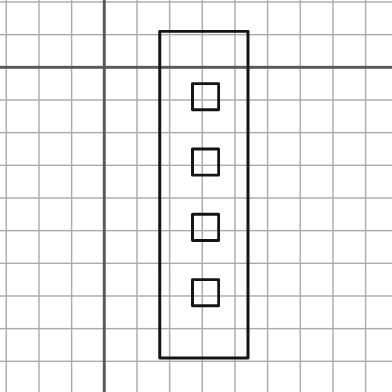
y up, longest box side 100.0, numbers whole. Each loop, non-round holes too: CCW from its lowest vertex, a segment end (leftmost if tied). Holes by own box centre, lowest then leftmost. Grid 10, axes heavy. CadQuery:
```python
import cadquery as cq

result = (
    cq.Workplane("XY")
    .moveTo(17.0, -89.0)
    .lineTo(44.0, -89.0)
    .lineTo(44.0, 11.0)
    .lineTo(17.0, 11.0)
    .close()
    .moveTo(27.0, -73.0)
    .lineTo(35.0, -73.0)
    .lineTo(35.0, -65.0)
    .lineTo(27.0, -65.0)
    .close()
    .moveTo(27.0, -53.0)
    .lineTo(35.0, -53.0)
    .lineTo(35.0, -45.0)
    .lineTo(27.0, -45.0)
    .close()
    .moveTo(27.0, -33.0)
    .lineTo(35.0, -33.0)
    .lineTo(35.0, -25.0)
    .lineTo(27.0, -25.0)
    .close()
    .moveTo(27.0, -13.0)
    .lineTo(35.0, -13.0)
    .lineTo(35.0, -5.0)
    .lineTo(27.0, -5.0)
    .close()
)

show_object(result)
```